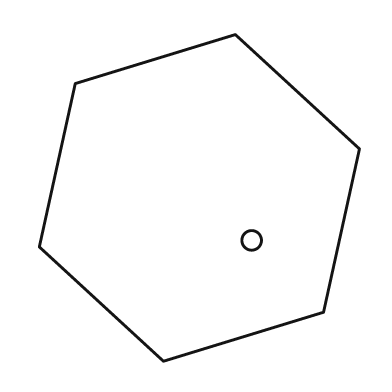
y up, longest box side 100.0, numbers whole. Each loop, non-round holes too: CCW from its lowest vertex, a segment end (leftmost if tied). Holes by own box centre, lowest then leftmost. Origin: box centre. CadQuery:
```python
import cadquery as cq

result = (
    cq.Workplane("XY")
    .moveTo(-11.0, -50.0)
    .lineTo(38.0, -35.0)
    .lineTo(49.0, 15.0)
    .lineTo(11.0, 50.0)
    .lineTo(-38.0, 35.0)
    .lineTo(-49.0, -15.0)
    .close()
    .moveTo(16.0, -13.0)
    .circle(3.0)
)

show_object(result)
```